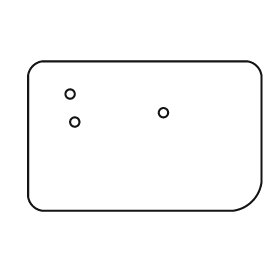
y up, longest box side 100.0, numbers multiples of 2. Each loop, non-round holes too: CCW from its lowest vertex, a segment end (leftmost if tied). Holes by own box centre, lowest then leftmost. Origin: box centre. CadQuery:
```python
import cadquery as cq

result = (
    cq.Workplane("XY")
    .moveTo(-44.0, -32.0)
    .lineTo(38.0, -32.0)
    .threePointArc((46.0, -28.0), (50.0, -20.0))
    .lineTo(50.0, 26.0)
    .threePointArc((48.0, 30.0), (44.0, 32.0))
    .lineTo(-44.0, 32.0)
    .threePointArc((-48.0, 30.0), (-50.0, 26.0))
    .lineTo(-50.0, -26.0)
    .threePointArc((-48.0, -30.0), (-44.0, -32.0))
    .close()
    .moveTo(-30.0, 6.0)
    .circle(2.0)
    .moveTo(8.0, 10.0)
    .circle(2.0)
    .moveTo(-32.0, 18.0)
    .circle(2.0)
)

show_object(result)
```